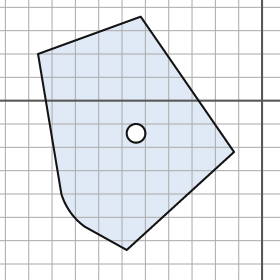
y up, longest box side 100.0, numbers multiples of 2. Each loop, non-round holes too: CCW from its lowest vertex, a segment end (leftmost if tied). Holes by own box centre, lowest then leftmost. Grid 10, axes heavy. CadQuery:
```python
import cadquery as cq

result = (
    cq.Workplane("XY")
    .moveTo(-58.0, -64.0)
    .lineTo(-12.0, -22.0)
    .lineTo(-52.0, 36.0)
    .lineTo(-96.0, 20.0)
    .lineTo(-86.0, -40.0)
    .threePointArc((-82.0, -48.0), (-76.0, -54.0))
    .close()
    .moveTo(-54.0, -14.0)
    .circle(4.0)
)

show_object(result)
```